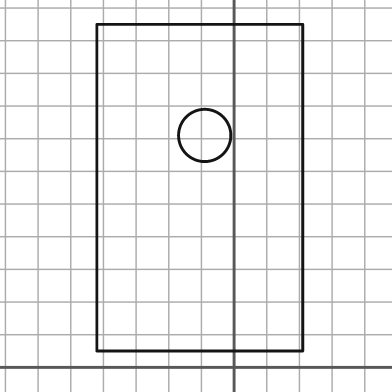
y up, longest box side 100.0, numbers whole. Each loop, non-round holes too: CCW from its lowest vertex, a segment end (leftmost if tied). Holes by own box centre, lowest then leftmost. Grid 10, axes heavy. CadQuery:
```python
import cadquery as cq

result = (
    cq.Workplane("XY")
    .moveTo(-42.0, 5.0)
    .lineTo(21.0, 5.0)
    .lineTo(21.0, 105.0)
    .lineTo(-42.0, 105.0)
    .close()
    .moveTo(-9.0, 71.0)
    .circle(8.0)
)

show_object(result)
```